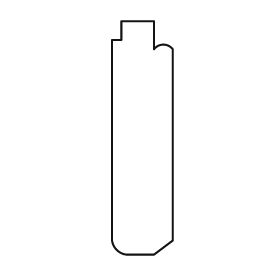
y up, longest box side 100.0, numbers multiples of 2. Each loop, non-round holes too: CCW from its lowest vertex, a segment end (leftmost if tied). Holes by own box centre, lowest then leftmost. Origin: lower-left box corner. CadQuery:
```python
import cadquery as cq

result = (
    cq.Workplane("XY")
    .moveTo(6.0, 0.0)
    .lineTo(18.0, 0.0)
    .lineTo(26.0, 6.0)
    .lineTo(26.0, 88.0)
    .threePointArc((22.0, 90.0), (18.0, 88.0))
    .lineTo(18.0, 100.0)
    .lineTo(4.0, 100.0)
    .lineTo(4.0, 92.0)
    .lineTo(0.0, 92.0)
    .lineTo(0.0, 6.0)
    .threePointArc((2.0, 2.0), (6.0, 0.0))
    .close()
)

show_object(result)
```